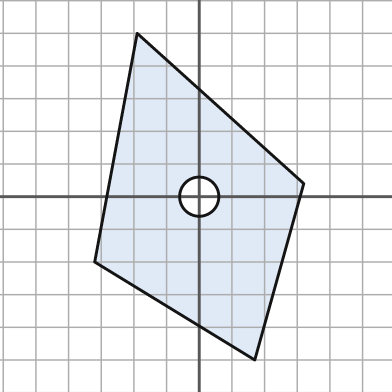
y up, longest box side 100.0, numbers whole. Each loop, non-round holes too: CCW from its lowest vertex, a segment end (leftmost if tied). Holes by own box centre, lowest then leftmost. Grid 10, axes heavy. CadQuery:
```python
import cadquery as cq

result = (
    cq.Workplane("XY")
    .moveTo(17.0, -50.0)
    .lineTo(32.0, 4.0)
    .lineTo(-19.0, 50.0)
    .lineTo(-32.0, -20.0)
    .close()
    .moveTo(0.0, 0.0)
    .circle(6.0)
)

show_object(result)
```